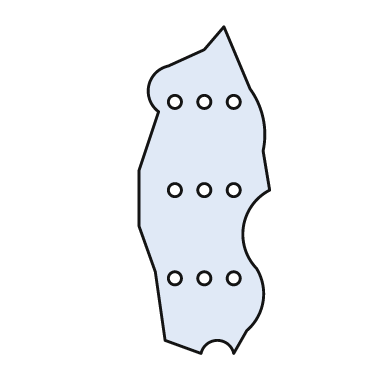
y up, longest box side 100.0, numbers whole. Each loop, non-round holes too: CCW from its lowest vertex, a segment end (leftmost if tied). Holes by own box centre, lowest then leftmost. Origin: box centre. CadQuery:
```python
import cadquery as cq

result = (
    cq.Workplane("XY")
    .moveTo(-1.0, -50.0)
    .threePointArc((4.0, -46.0), (9.0, -50.0))
    .lineTo(13.0, -43.0)
    .threePointArc((18.0, -34.0), (16.0, -24.0))
    .threePointArc((12.0, -11.0), (20.0, 0.0))
    .lineTo(18.0, 12.0)
    .threePointArc((18.0, 22.0), (14.0, 31.0))
    .lineTo(6.0, 50.0)
    .lineTo(0.0, 43.0)
    .lineTo(-11.0, 38.0)
    .threePointArc((-17.0, 32.0), (-14.0, 24.0))
    .lineTo(-20.0, 6.0)
    .lineTo(-20.0, -11.0)
    .lineTo(-15.0, -25.0)
    .lineTo(-12.0, -46.0)
    .close()
    .moveTo(-9.0, -27.0)
    .circle(2.0)
    .moveTo(0.0, -27.0)
    .circle(2.0)
    .moveTo(9.0, -27.0)
    .circle(2.0)
    .moveTo(-9.0, 0.0)
    .circle(2.0)
    .moveTo(0.0, 0.0)
    .circle(2.0)
    .moveTo(9.0, 0.0)
    .circle(2.0)
    .moveTo(-9.0, 27.0)
    .circle(2.0)
    .moveTo(0.0, 27.0)
    .circle(2.0)
    .moveTo(9.0, 27.0)
    .circle(2.0)
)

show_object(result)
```